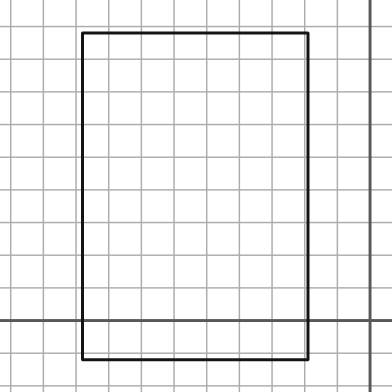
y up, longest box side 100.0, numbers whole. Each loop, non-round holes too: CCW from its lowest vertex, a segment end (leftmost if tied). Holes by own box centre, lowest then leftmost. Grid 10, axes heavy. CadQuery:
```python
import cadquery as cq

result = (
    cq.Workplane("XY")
    .moveTo(-88.0, -12.0)
    .lineTo(-19.0, -12.0)
    .lineTo(-19.0, 88.0)
    .lineTo(-88.0, 88.0)
    .close()
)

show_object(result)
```